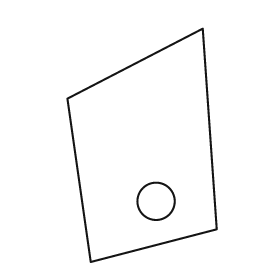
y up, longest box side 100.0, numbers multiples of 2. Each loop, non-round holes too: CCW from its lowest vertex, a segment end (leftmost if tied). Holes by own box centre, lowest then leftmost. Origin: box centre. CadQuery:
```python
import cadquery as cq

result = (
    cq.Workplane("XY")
    .moveTo(-22.0, -50.0)
    .lineTo(32.0, -36.0)
    .lineTo(26.0, 50.0)
    .lineTo(-32.0, 20.0)
    .close()
    .moveTo(6.0, -24.0)
    .circle(8.0)
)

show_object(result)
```